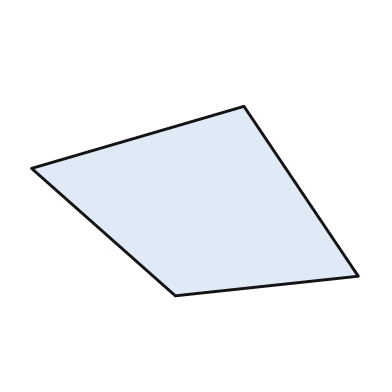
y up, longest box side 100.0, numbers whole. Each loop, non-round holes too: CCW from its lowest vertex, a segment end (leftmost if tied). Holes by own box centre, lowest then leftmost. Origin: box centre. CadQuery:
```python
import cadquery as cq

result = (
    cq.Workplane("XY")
    .moveTo(-6.0, -29.0)
    .lineTo(50.0, -23.0)
    .lineTo(15.0, 29.0)
    .lineTo(-50.0, 10.0)
    .close()
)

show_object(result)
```